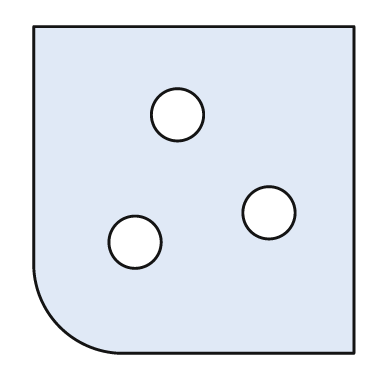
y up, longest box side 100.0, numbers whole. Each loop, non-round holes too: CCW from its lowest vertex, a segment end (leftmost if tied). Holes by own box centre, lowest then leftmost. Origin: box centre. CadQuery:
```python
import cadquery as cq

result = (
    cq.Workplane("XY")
    .moveTo(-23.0, -50.0)
    .lineTo(49.0, -50.0)
    .lineTo(49.0, 50.0)
    .lineTo(-49.0, 50.0)
    .lineTo(-49.0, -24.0)
    .threePointArc((-41.0, -42.0), (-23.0, -50.0))
    .close()
    .moveTo(-18.0, -16.0)
    .circle(8.0)
    .moveTo(23.0, -7.0)
    .circle(8.0)
    .moveTo(-5.0, 23.0)
    .circle(8.0)
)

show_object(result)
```